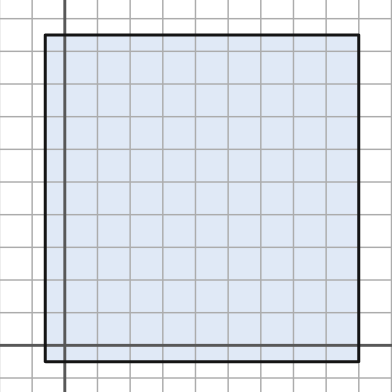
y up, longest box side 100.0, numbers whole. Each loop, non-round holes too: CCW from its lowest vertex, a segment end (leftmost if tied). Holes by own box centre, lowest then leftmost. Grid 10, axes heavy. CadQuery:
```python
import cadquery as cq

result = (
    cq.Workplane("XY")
    .moveTo(-6.0, -5.0)
    .lineTo(90.0, -5.0)
    .lineTo(90.0, 95.0)
    .lineTo(-6.0, 95.0)
    .close()
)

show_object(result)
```